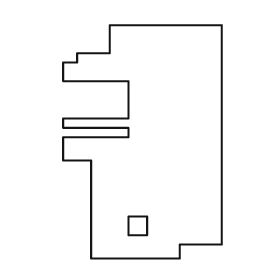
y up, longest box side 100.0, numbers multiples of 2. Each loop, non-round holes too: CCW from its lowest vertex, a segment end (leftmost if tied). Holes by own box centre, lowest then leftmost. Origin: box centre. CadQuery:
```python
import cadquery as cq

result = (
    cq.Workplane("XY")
    .moveTo(-22.0, -50.0)
    .lineTo(16.0, -50.0)
    .lineTo(16.0, -44.0)
    .lineTo(34.0, -44.0)
    .lineTo(34.0, 50.0)
    .lineTo(-14.0, 50.0)
    .lineTo(-14.0, 38.0)
    .lineTo(-28.0, 38.0)
    .lineTo(-28.0, 34.0)
    .lineTo(-34.0, 34.0)
    .lineTo(-34.0, 26.0)
    .lineTo(-6.0, 26.0)
    .lineTo(-6.0, 10.0)
    .lineTo(-34.0, 10.0)
    .lineTo(-34.0, 6.0)
    .lineTo(-6.0, 6.0)
    .lineTo(-6.0, 2.0)
    .lineTo(-34.0, 2.0)
    .lineTo(-34.0, -8.0)
    .lineTo(-22.0, -8.0)
    .close()
    .moveTo(-6.0, -40.0)
    .lineTo(2.0, -40.0)
    .lineTo(2.0, -32.0)
    .lineTo(-6.0, -32.0)
    .close()
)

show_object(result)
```